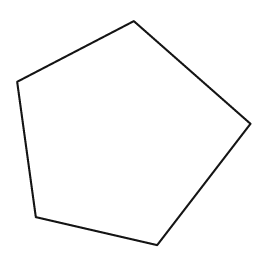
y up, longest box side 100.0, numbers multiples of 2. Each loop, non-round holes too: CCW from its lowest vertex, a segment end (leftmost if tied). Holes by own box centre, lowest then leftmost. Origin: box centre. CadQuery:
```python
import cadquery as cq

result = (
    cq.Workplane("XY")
    .moveTo(10.0, -48.0)
    .lineTo(50.0, 4.0)
    .lineTo(0.0, 48.0)
    .lineTo(-50.0, 22.0)
    .lineTo(-42.0, -36.0)
    .close()
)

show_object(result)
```